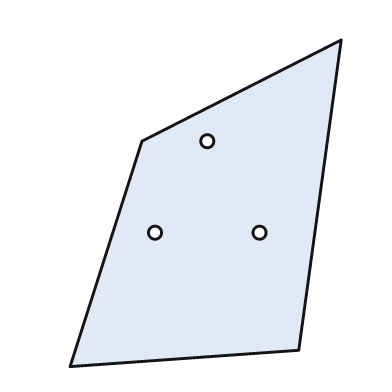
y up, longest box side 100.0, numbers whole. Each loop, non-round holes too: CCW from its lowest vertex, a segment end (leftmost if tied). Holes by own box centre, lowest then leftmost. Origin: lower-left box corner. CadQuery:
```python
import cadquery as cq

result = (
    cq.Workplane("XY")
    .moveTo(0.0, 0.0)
    .lineTo(70.0, 5.0)
    .lineTo(83.0, 100.0)
    .lineTo(22.0, 69.0)
    .close()
    .moveTo(26.0, 41.0)
    .circle(2.0)
    .moveTo(58.0, 41.0)
    .circle(2.0)
    .moveTo(42.0, 69.0)
    .circle(2.0)
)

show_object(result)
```